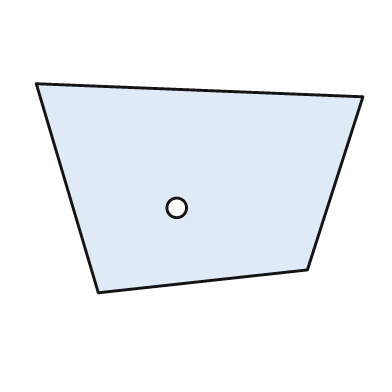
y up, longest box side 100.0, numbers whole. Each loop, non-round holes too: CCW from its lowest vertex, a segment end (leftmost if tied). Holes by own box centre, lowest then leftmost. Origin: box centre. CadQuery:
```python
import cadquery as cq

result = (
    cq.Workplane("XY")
    .moveTo(-31.0, -32.0)
    .lineTo(33.0, -25.0)
    .lineTo(50.0, 28.0)
    .lineTo(-50.0, 32.0)
    .close()
    .moveTo(-7.0, -6.0)
    .circle(3.0)
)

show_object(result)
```